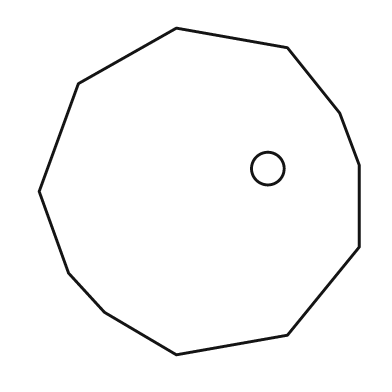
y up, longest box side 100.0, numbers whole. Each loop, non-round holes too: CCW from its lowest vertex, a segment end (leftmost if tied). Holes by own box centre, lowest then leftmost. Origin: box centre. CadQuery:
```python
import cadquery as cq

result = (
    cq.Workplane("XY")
    .moveTo(-7.0, -50.0)
    .lineTo(27.0, -44.0)
    .lineTo(49.0, -17.0)
    .lineTo(49.0, 8.0)
    .lineTo(43.0, 24.0)
    .lineTo(27.0, 44.0)
    .lineTo(-7.0, 50.0)
    .lineTo(-37.0, 33.0)
    .lineTo(-49.0, 0.0)
    .lineTo(-40.0, -25.0)
    .lineTo(-29.0, -37.0)
    .close()
    .moveTo(21.0, 7.0)
    .circle(5.0)
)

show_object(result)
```